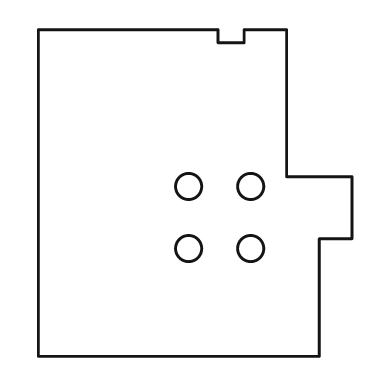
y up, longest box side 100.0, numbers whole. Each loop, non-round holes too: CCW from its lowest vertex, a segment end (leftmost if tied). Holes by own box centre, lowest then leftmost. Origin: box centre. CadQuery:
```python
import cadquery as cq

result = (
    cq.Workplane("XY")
    .moveTo(-48.0, -50.0)
    .lineTo(38.0, -50.0)
    .lineTo(38.0, -14.0)
    .lineTo(48.0, -14.0)
    .lineTo(48.0, 5.0)
    .lineTo(28.0, 5.0)
    .lineTo(28.0, 50.0)
    .lineTo(15.0, 50.0)
    .lineTo(15.0, 46.0)
    .lineTo(7.0, 46.0)
    .lineTo(7.0, 50.0)
    .lineTo(-48.0, 50.0)
    .close()
    .moveTo(-2.0, -17.0)
    .circle(4.0)
    .moveTo(17.0, -17.0)
    .circle(4.0)
    .moveTo(-2.0, 2.0)
    .circle(4.0)
    .moveTo(17.0, 2.0)
    .circle(4.0)
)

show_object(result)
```